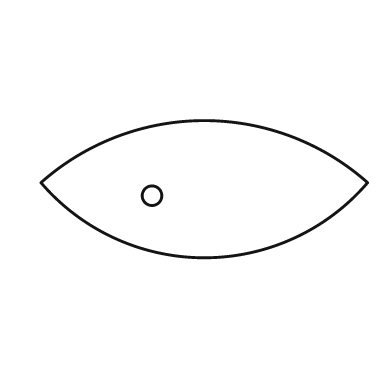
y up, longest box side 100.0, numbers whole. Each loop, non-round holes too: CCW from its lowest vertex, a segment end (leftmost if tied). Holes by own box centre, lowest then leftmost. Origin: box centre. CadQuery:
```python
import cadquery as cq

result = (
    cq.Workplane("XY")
    .moveTo(-50.0, 2.0)
    .threePointArc((0.0, -21.0), (50.0, 2.0))
    .threePointArc((0.0, 21.0), (-50.0, 2.0))
    .close()
    .moveTo(-16.0, -2.0)
    .circle(3.0)
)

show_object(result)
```